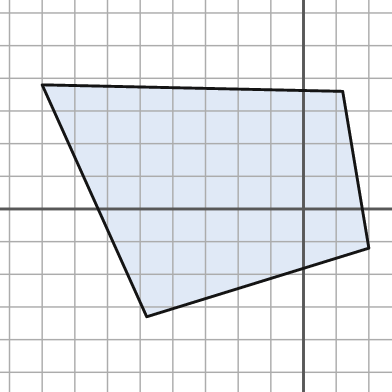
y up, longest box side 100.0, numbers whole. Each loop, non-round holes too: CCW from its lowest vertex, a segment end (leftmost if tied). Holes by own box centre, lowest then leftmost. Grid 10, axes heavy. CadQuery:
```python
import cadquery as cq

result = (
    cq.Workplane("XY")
    .moveTo(-48.0, -33.0)
    .lineTo(20.0, -12.0)
    .lineTo(12.0, 36.0)
    .lineTo(-80.0, 38.0)
    .close()
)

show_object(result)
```